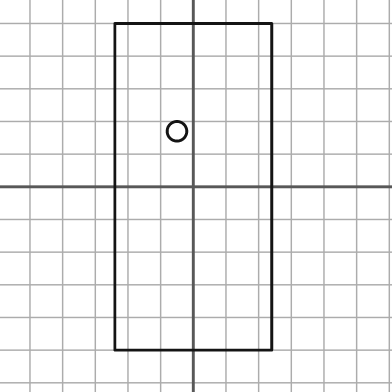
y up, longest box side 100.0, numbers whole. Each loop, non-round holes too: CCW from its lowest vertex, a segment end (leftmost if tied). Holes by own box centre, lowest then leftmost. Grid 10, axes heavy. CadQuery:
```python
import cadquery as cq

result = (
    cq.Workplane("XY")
    .moveTo(-24.0, -50.0)
    .lineTo(24.0, -50.0)
    .lineTo(24.0, 50.0)
    .lineTo(-24.0, 50.0)
    .close()
    .moveTo(-5.0, 17.0)
    .circle(3.0)
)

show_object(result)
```